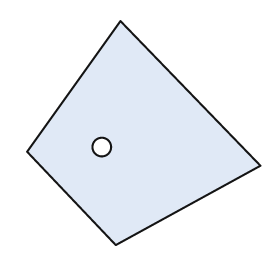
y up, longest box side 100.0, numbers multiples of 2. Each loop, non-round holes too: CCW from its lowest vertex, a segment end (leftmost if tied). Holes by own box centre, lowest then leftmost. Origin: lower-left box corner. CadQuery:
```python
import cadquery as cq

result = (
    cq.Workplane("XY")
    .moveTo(38.0, 0.0)
    .lineTo(100.0, 34.0)
    .lineTo(40.0, 96.0)
    .lineTo(0.0, 40.0)
    .close()
    .moveTo(32.0, 42.0)
    .circle(4.0)
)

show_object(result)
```